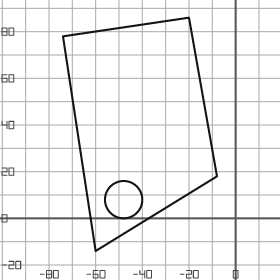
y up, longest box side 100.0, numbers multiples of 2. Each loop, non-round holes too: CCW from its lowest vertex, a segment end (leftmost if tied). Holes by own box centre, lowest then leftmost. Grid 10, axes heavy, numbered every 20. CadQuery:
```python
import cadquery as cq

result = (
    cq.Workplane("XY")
    .moveTo(-60.0, -14.0)
    .lineTo(-8.0, 18.0)
    .lineTo(-20.0, 86.0)
    .lineTo(-74.0, 78.0)
    .close()
    .moveTo(-48.0, 8.0)
    .circle(8.0)
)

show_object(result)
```